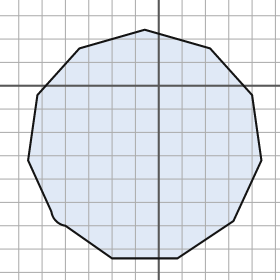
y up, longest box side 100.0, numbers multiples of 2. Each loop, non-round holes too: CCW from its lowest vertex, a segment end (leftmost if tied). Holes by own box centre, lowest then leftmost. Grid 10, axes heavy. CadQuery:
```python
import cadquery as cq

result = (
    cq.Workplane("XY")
    .moveTo(-20.0, -74.0)
    .lineTo(8.0, -74.0)
    .lineTo(32.0, -58.0)
    .lineTo(44.0, -32.0)
    .lineTo(40.0, -4.0)
    .lineTo(22.0, 16.0)
    .lineTo(-6.0, 24.0)
    .lineTo(-34.0, 16.0)
    .lineTo(-52.0, -4.0)
    .lineTo(-56.0, -32.0)
    .lineTo(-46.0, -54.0)
    .threePointArc((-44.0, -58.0), (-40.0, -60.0))
    .close()
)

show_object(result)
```